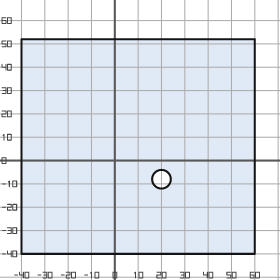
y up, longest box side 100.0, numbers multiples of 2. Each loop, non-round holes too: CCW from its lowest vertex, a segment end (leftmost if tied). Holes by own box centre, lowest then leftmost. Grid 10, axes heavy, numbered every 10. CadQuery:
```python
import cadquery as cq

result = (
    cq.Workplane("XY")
    .moveTo(-40.0, -40.0)
    .lineTo(60.0, -40.0)
    .lineTo(60.0, 52.0)
    .lineTo(-40.0, 52.0)
    .close()
    .moveTo(20.0, -8.0)
    .circle(4.0)
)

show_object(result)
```